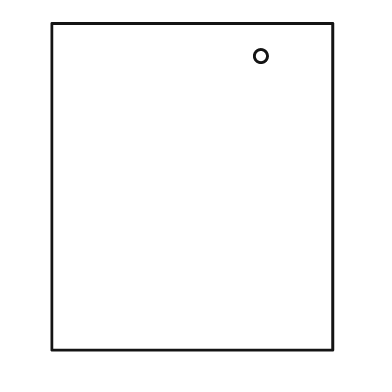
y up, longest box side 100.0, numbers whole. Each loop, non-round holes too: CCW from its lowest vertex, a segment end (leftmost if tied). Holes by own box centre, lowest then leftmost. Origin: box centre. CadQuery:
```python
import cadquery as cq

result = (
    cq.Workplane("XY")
    .moveTo(-43.0, -50.0)
    .lineTo(43.0, -50.0)
    .lineTo(43.0, 50.0)
    .lineTo(-43.0, 50.0)
    .close()
    .moveTo(21.0, 40.0)
    .circle(2.0)
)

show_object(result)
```